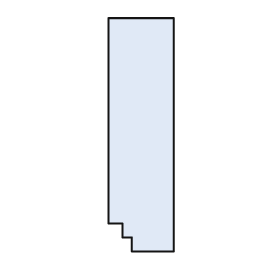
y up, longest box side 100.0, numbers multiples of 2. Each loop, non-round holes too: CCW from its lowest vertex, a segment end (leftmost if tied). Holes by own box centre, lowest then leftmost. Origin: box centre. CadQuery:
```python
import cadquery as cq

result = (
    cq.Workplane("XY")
    .moveTo(-4.0, -50.0)
    .lineTo(14.0, -50.0)
    .lineTo(14.0, 50.0)
    .lineTo(-14.0, 50.0)
    .lineTo(-14.0, -38.0)
    .lineTo(-8.0, -38.0)
    .lineTo(-8.0, -44.0)
    .lineTo(-4.0, -44.0)
    .close()
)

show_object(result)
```